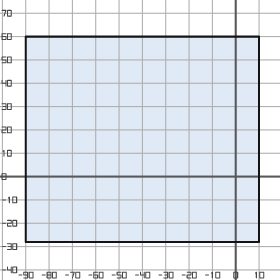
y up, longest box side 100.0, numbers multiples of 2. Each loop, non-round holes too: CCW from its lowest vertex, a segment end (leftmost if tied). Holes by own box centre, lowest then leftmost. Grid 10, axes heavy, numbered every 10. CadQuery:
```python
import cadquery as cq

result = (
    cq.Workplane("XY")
    .moveTo(-90.0, -28.0)
    .lineTo(10.0, -28.0)
    .lineTo(10.0, 60.0)
    .lineTo(-90.0, 60.0)
    .close()
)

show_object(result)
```